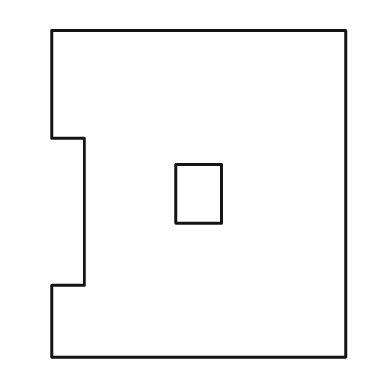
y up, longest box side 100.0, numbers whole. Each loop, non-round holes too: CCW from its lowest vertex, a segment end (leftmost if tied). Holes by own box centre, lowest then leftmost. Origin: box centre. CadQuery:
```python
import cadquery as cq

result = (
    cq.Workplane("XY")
    .moveTo(-45.0, -50.0)
    .lineTo(45.0, -50.0)
    .lineTo(45.0, 50.0)
    .lineTo(-45.0, 50.0)
    .lineTo(-45.0, 17.0)
    .lineTo(-35.0, 17.0)
    .lineTo(-35.0, -28.0)
    .lineTo(-45.0, -28.0)
    .close()
    .moveTo(-7.0, -9.0)
    .lineTo(7.0, -9.0)
    .lineTo(7.0, 9.0)
    .lineTo(-7.0, 9.0)
    .close()
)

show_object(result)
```